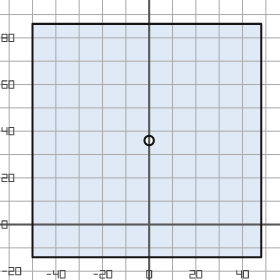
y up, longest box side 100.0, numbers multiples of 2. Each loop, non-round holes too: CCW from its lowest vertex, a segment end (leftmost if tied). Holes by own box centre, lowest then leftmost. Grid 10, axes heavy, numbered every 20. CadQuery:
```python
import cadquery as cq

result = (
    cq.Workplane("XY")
    .moveTo(-50.0, -14.0)
    .lineTo(48.0, -14.0)
    .lineTo(48.0, 86.0)
    .lineTo(-50.0, 86.0)
    .close()
    .moveTo(0.0, 36.0)
    .circle(2.0)
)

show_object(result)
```